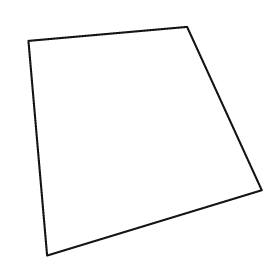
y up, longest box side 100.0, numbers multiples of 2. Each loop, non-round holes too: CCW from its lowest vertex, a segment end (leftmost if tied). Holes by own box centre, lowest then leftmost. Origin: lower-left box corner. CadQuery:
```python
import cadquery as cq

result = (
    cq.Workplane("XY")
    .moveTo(8.0, 0.0)
    .lineTo(100.0, 28.0)
    .lineTo(68.0, 98.0)
    .lineTo(0.0, 92.0)
    .close()
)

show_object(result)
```